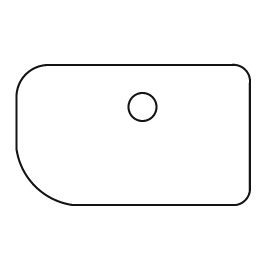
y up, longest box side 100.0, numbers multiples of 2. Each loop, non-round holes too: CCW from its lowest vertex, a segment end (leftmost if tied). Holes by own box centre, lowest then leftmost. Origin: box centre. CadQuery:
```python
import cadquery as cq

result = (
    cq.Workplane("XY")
    .moveTo(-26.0, -30.0)
    .lineTo(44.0, -30.0)
    .threePointArc((48.0, -28.0), (50.0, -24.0))
    .lineTo(50.0, 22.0)
    .threePointArc((48.0, 28.0), (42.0, 30.0))
    .lineTo(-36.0, 30.0)
    .threePointArc((-46.0, 26.0), (-50.0, 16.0))
    .lineTo(-50.0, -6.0)
    .threePointArc((-42.0, -22.0), (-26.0, -30.0))
    .close()
    .moveTo(4.0, 12.0)
    .circle(6.0)
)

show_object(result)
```